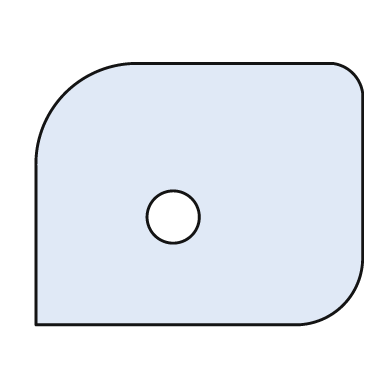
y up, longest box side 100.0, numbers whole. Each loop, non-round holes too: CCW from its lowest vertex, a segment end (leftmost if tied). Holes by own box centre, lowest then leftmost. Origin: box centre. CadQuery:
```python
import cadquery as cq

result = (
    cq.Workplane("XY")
    .moveTo(-50.0, -40.0)
    .lineTo(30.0, -40.0)
    .threePointArc((44.0, -34.0), (50.0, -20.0))
    .lineTo(50.0, 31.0)
    .threePointArc((47.0, 37.0), (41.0, 40.0))
    .lineTo(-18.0, 40.0)
    .threePointArc((-41.0, 31.0), (-50.0, 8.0))
    .close()
    .moveTo(-8.0, -7.0)
    .circle(8.0)
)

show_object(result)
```